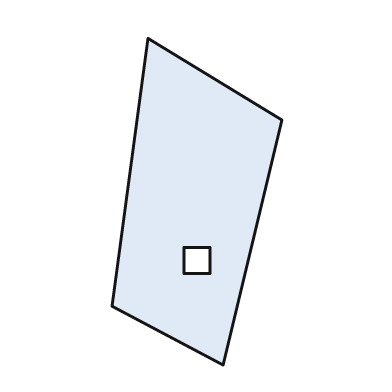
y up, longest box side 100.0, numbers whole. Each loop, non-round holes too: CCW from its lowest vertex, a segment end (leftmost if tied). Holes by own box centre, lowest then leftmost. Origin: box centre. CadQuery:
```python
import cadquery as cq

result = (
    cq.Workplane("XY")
    .moveTo(8.0, -50.0)
    .lineTo(26.0, 25.0)
    .lineTo(-15.0, 50.0)
    .lineTo(-26.0, -32.0)
    .close()
    .moveTo(-4.0, -22.0)
    .lineTo(4.0, -22.0)
    .lineTo(4.0, -14.0)
    .lineTo(-4.0, -14.0)
    .close()
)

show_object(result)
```